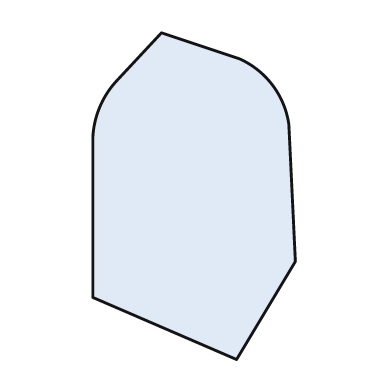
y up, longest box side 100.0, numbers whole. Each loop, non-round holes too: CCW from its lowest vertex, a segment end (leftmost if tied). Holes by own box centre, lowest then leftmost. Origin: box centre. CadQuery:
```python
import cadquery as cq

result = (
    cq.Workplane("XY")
    .moveTo(13.0, -50.0)
    .lineTo(31.0, -20.0)
    .lineTo(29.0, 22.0)
    .threePointArc((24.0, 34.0), (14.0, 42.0))
    .lineTo(-10.0, 50.0)
    .lineTo(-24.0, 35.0)
    .threePointArc((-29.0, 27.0), (-31.0, 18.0))
    .lineTo(-31.0, -31.0)
    .close()
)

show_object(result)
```